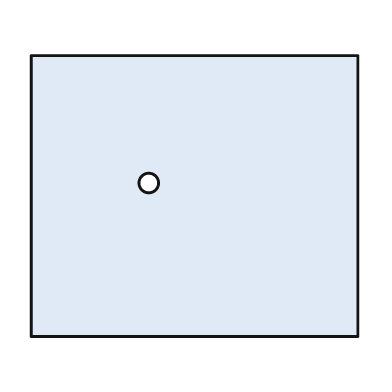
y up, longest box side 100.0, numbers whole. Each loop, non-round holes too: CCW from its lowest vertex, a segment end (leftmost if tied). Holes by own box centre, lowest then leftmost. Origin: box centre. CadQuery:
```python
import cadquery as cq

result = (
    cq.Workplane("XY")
    .moveTo(-50.0, -43.0)
    .lineTo(50.0, -43.0)
    .lineTo(50.0, 43.0)
    .lineTo(-50.0, 43.0)
    .close()
    .moveTo(-14.0, 4.0)
    .circle(3.0)
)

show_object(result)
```